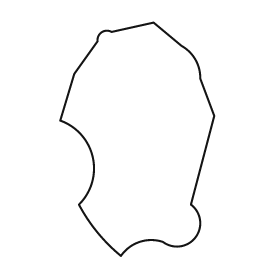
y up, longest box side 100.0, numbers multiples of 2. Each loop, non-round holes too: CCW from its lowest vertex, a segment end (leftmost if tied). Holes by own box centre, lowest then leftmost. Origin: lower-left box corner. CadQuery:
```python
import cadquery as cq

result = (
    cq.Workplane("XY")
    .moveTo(26.0, 0.0)
    .threePointArc((34.0, 6.0), (44.0, 6.0))
    .threePointArc((58.0, 8.0), (56.0, 22.0))
    .lineTo(66.0, 60.0)
    .lineTo(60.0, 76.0)
    .threePointArc((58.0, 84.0), (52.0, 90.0))
    .lineTo(40.0, 100.0)
    .lineTo(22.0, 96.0)
    .threePointArc((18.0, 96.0), (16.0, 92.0))
    .lineTo(6.0, 78.0)
    .lineTo(0.0, 58.0)
    .threePointArc((14.0, 42.0), (8.0, 22.0))
    .threePointArc((16.0, 10.0), (26.0, 0.0))
    .close()
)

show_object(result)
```